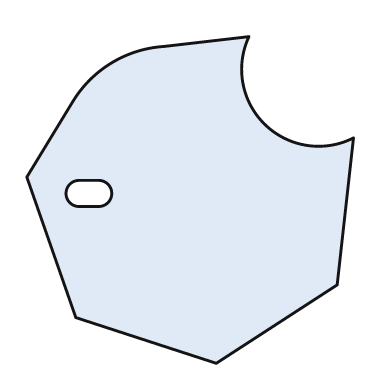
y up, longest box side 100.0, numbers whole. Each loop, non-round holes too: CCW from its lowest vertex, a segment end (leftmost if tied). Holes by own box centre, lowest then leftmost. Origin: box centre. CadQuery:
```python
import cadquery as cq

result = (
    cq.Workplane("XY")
    .moveTo(8.0, -50.0)
    .lineTo(45.0, -26.0)
    .lineTo(50.0, 19.0)
    .threePointArc((23.0, 23.0), (18.0, 50.0))
    .lineTo(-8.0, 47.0)
    .threePointArc((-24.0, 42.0), (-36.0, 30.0))
    .lineTo(-50.0, 7.0)
    .lineTo(-35.0, -36.0)
    .close()
    .moveTo(-34.0, -2.0)
    .lineTo(-28.0, -2.0)
    .threePointArc((-24.0, 2.0), (-28.0, 6.0))
    .lineTo(-34.0, 6.0)
    .threePointArc((-38.0, 2.0), (-34.0, -2.0))
    .close()
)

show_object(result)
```